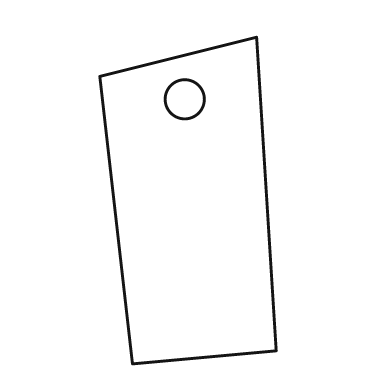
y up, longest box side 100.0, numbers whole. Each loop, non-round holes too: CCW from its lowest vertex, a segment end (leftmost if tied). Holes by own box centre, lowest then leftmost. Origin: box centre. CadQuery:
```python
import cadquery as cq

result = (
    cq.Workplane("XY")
    .moveTo(-17.0, -50.0)
    .lineTo(27.0, -46.0)
    .lineTo(21.0, 50.0)
    .lineTo(-27.0, 38.0)
    .close()
    .moveTo(-1.0, 31.0)
    .circle(6.0)
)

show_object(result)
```